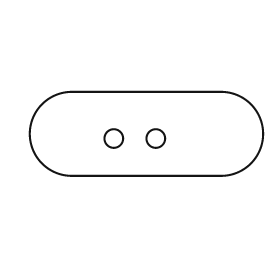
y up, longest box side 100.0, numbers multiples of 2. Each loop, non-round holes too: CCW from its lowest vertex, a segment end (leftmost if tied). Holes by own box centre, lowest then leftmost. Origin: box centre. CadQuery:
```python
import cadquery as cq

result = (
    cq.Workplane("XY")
    .moveTo(-32.0, -18.0)
    .lineTo(32.0, -18.0)
    .threePointArc((50.0, 0.0), (32.0, 18.0))
    .lineTo(-32.0, 18.0)
    .threePointArc((-50.0, 0.0), (-32.0, -18.0))
    .close()
    .moveTo(-14.0, -2.0)
    .circle(4.0)
    .moveTo(4.0, -2.0)
    .circle(4.0)
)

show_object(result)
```